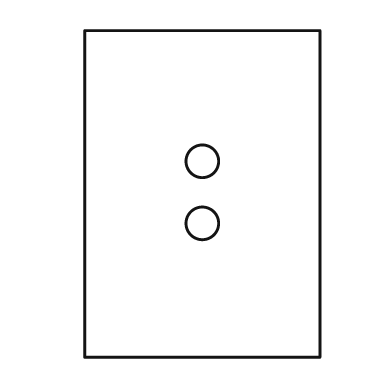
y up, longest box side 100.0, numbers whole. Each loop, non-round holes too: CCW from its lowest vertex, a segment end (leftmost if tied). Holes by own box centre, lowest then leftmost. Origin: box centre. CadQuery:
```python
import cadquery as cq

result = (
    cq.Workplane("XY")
    .moveTo(-36.0, -50.0)
    .lineTo(36.0, -50.0)
    .lineTo(36.0, 50.0)
    .lineTo(-36.0, 50.0)
    .close()
    .moveTo(0.0, -9.0)
    .circle(5.0)
    .moveTo(0.0, 10.0)
    .circle(5.0)
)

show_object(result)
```